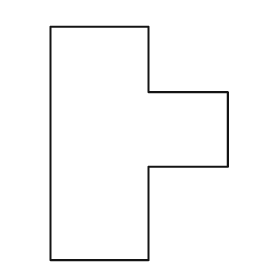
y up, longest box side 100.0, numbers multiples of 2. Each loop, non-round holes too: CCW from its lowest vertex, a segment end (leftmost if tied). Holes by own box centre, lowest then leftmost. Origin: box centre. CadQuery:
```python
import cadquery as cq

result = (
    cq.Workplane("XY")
    .moveTo(-38.0, -50.0)
    .lineTo(4.0, -50.0)
    .lineTo(4.0, -10.0)
    .lineTo(38.0, -10.0)
    .lineTo(38.0, 22.0)
    .lineTo(4.0, 22.0)
    .lineTo(4.0, 50.0)
    .lineTo(-38.0, 50.0)
    .close()
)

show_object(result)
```